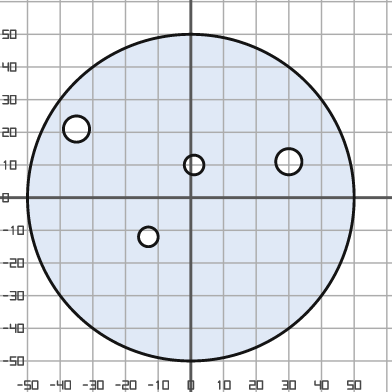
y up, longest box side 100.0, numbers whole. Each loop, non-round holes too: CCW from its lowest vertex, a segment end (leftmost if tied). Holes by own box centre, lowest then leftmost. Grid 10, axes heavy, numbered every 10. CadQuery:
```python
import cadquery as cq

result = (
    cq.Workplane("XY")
    .moveTo(0.0, 0.0)
    .circle(50.0)
    .moveTo(-13.0, -12.0)
    .circle(3.0)
    .moveTo(1.0, 10.0)
    .circle(3.0)
    .moveTo(30.0, 11.0)
    .circle(4.0)
    .moveTo(-35.0, 21.0)
    .circle(4.0)
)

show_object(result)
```